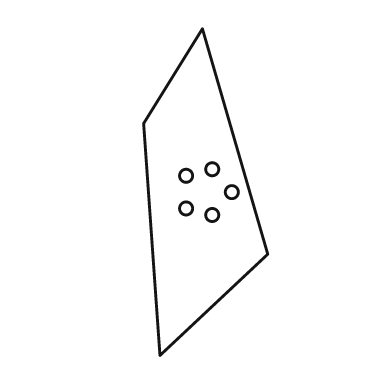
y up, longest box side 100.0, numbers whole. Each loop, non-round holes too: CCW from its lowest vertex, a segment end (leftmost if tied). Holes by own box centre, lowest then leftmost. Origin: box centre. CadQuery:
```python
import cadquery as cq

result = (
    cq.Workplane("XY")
    .moveTo(-14.0, -50.0)
    .lineTo(19.0, -19.0)
    .lineTo(-1.0, 50.0)
    .lineTo(-19.0, 21.0)
    .close()
    .moveTo(2.0, -7.0)
    .circle(2.0)
    .moveTo(-6.0, -5.0)
    .circle(2.0)
    .moveTo(8.0, 0.0)
    .circle(2.0)
    .moveTo(-6.0, 5.0)
    .circle(2.0)
    .moveTo(2.0, 7.0)
    .circle(2.0)
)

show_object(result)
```